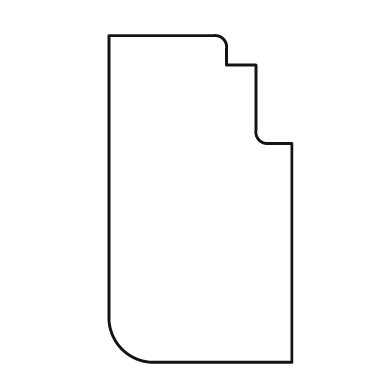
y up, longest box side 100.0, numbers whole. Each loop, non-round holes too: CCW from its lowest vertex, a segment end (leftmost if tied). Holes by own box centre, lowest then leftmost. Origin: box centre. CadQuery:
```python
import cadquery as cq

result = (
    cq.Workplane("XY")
    .moveTo(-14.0, -50.0)
    .lineTo(28.0, -50.0)
    .lineTo(28.0, 17.0)
    .lineTo(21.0, 17.0)
    .threePointArc((18.0, 18.0), (17.0, 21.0))
    .lineTo(17.0, 41.0)
    .lineTo(8.0, 41.0)
    .lineTo(8.0, 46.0)
    .threePointArc((7.0, 49.0), (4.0, 50.0))
    .lineTo(-28.0, 50.0)
    .lineTo(-28.0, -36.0)
    .threePointArc((-24.0, -46.0), (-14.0, -50.0))
    .close()
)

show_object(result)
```